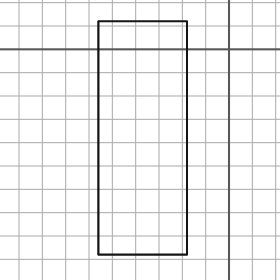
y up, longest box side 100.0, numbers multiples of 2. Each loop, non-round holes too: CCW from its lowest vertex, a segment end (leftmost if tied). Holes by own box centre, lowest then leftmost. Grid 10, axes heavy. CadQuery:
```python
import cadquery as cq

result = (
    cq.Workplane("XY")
    .moveTo(-56.0, -88.0)
    .lineTo(-18.0, -88.0)
    .lineTo(-18.0, 12.0)
    .lineTo(-56.0, 12.0)
    .close()
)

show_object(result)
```